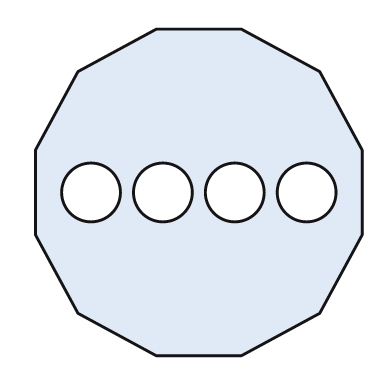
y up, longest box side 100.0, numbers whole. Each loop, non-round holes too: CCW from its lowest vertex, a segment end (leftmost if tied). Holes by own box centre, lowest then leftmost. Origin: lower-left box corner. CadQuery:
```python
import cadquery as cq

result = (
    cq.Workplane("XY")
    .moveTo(37.0, 0.0)
    .lineTo(63.0, 0.0)
    .lineTo(87.0, 13.0)
    .lineTo(100.0, 37.0)
    .lineTo(100.0, 63.0)
    .lineTo(87.0, 87.0)
    .lineTo(63.0, 100.0)
    .lineTo(37.0, 100.0)
    .lineTo(13.0, 87.0)
    .lineTo(0.0, 63.0)
    .lineTo(0.0, 37.0)
    .lineTo(13.0, 13.0)
    .close()
    .moveTo(17.0, 50.0)
    .circle(9.0)
    .moveTo(39.0, 50.0)
    .circle(9.0)
    .moveTo(61.0, 50.0)
    .circle(9.0)
    .moveTo(83.0, 50.0)
    .circle(9.0)
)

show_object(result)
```